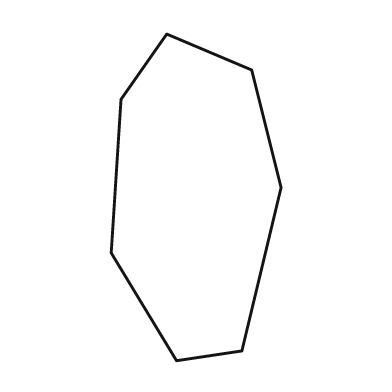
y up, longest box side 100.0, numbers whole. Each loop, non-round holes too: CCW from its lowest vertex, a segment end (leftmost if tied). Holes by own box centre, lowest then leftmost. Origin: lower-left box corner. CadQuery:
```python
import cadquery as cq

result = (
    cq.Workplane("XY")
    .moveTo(20.0, 0.0)
    .lineTo(40.0, 3.0)
    .lineTo(52.0, 53.0)
    .lineTo(43.0, 89.0)
    .lineTo(17.0, 100.0)
    .lineTo(3.0, 80.0)
    .lineTo(0.0, 33.0)
    .close()
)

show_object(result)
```